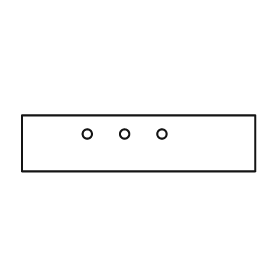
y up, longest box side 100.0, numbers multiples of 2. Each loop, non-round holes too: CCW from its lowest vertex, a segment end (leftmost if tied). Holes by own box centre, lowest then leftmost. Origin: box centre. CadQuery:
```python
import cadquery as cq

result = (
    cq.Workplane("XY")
    .moveTo(-50.0, -12.0)
    .lineTo(50.0, -12.0)
    .lineTo(50.0, 12.0)
    .lineTo(-50.0, 12.0)
    .close()
    .moveTo(-22.0, 4.0)
    .circle(2.0)
    .moveTo(-6.0, 4.0)
    .circle(2.0)
    .moveTo(10.0, 4.0)
    .circle(2.0)
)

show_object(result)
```